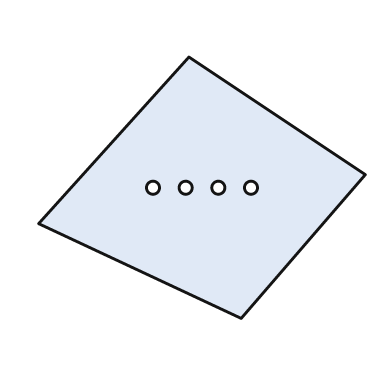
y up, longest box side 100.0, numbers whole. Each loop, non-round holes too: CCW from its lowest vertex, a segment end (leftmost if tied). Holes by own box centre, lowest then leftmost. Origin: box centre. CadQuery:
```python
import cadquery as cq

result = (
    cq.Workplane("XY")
    .moveTo(12.0, -40.0)
    .lineTo(50.0, 4.0)
    .lineTo(-4.0, 40.0)
    .lineTo(-50.0, -11.0)
    .close()
    .moveTo(-15.0, 0.0)
    .circle(2.0)
    .moveTo(-5.0, 0.0)
    .circle(2.0)
    .moveTo(5.0, 0.0)
    .circle(2.0)
    .moveTo(15.0, 0.0)
    .circle(2.0)
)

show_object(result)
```